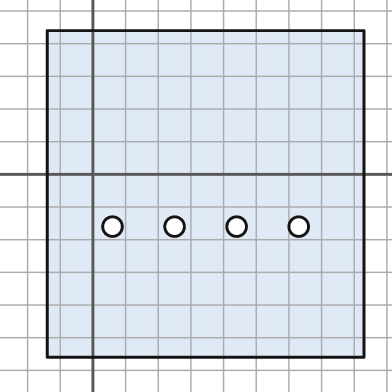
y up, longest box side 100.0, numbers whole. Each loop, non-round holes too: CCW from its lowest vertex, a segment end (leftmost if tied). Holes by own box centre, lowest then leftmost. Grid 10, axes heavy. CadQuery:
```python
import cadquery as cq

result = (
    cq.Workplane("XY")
    .moveTo(-14.0, -56.0)
    .lineTo(83.0, -56.0)
    .lineTo(83.0, 44.0)
    .lineTo(-14.0, 44.0)
    .close()
    .moveTo(6.0, -16.0)
    .circle(3.0)
    .moveTo(25.0, -16.0)
    .circle(3.0)
    .moveTo(44.0, -16.0)
    .circle(3.0)
    .moveTo(63.0, -16.0)
    .circle(3.0)
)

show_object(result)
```